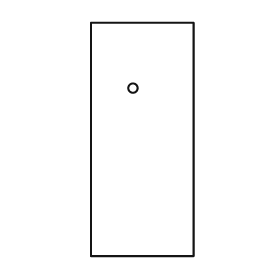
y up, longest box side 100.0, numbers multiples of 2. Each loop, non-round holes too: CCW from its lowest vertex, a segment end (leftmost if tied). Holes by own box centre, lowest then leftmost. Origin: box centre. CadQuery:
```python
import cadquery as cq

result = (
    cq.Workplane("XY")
    .moveTo(-22.0, -50.0)
    .lineTo(22.0, -50.0)
    .lineTo(22.0, 50.0)
    .lineTo(-22.0, 50.0)
    .close()
    .moveTo(-4.0, 22.0)
    .circle(2.0)
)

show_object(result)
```